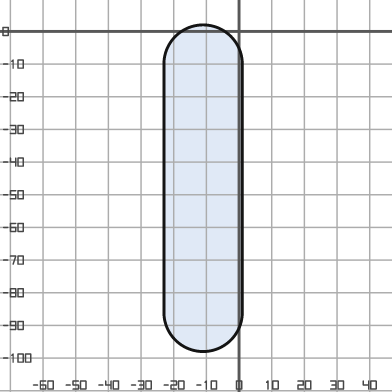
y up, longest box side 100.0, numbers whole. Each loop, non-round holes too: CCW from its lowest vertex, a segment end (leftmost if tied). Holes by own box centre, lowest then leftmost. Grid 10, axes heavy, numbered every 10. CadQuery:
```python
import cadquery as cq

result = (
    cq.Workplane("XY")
    .moveTo(-23.0, -86.0)
    .threePointArc((-11.0, -98.0), (1.0, -86.0))
    .lineTo(1.0, -10.0)
    .threePointArc((-11.0, 2.0), (-23.0, -10.0))
    .close()
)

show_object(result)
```